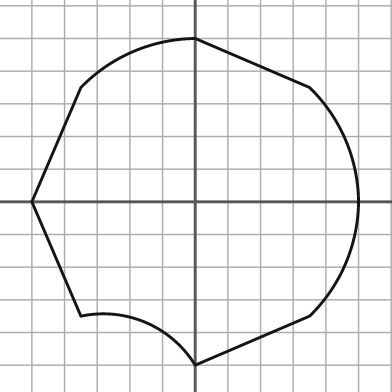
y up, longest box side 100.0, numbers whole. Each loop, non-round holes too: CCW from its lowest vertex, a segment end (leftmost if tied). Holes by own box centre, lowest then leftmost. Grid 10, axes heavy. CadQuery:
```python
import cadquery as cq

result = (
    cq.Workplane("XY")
    .moveTo(0.0, -50.0)
    .lineTo(35.0, -35.0)
    .threePointArc((46.0, -19.0), (50.0, 0.0))
    .threePointArc((46.0, 19.0), (35.0, 35.0))
    .lineTo(0.0, 50.0)
    .threePointArc((-19.0, 46.0), (-35.0, 35.0))
    .lineTo(-50.0, 0.0)
    .lineTo(-35.0, -35.0)
    .threePointArc((-15.0, -37.0), (0.0, -50.0))
    .close()
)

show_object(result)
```